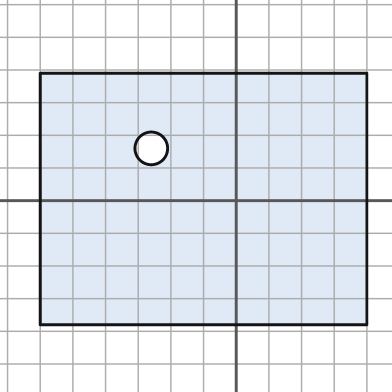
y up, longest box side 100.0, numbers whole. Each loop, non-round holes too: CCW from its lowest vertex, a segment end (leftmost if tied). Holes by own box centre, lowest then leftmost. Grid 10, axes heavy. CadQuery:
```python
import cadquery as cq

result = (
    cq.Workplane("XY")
    .moveTo(-60.0, -38.0)
    .lineTo(40.0, -38.0)
    .lineTo(40.0, 39.0)
    .lineTo(-60.0, 39.0)
    .close()
    .moveTo(-26.0, 16.0)
    .circle(5.0)
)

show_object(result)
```